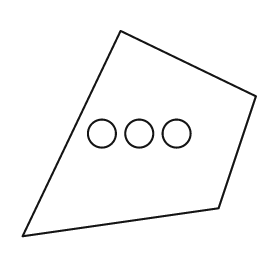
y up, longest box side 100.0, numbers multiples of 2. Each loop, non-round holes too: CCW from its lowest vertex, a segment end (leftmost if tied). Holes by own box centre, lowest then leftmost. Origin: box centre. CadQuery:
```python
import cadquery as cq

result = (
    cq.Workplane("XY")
    .moveTo(-50.0, -44.0)
    .lineTo(34.0, -32.0)
    .lineTo(50.0, 16.0)
    .lineTo(-8.0, 44.0)
    .close()
    .moveTo(-16.0, 0.0)
    .circle(6.0)
    .moveTo(0.0, 0.0)
    .circle(6.0)
    .moveTo(16.0, 0.0)
    .circle(6.0)
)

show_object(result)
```